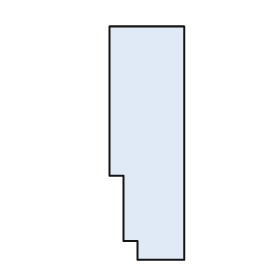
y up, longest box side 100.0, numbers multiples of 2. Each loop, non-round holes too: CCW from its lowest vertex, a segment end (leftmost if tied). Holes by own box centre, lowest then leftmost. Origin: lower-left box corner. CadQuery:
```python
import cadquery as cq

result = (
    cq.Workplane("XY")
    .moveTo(12.0, 0.0)
    .lineTo(32.0, 0.0)
    .lineTo(32.0, 100.0)
    .lineTo(0.0, 100.0)
    .lineTo(0.0, 36.0)
    .lineTo(6.0, 36.0)
    .lineTo(6.0, 8.0)
    .lineTo(12.0, 8.0)
    .close()
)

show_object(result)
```